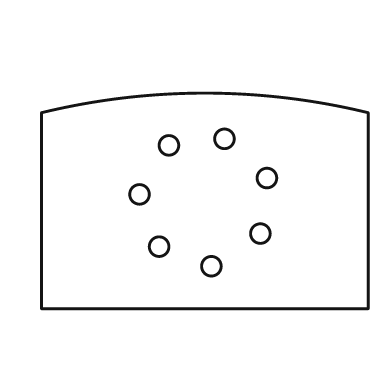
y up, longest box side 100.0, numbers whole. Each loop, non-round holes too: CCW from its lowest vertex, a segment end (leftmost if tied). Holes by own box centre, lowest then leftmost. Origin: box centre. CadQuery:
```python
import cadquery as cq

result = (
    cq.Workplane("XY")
    .moveTo(-50.0, -33.0)
    .lineTo(50.0, -33.0)
    .lineTo(50.0, 27.0)
    .threePointArc((0.0, 33.0), (-50.0, 27.0))
    .close()
    .moveTo(2.0, -20.0)
    .circle(3.0)
    .moveTo(-14.0, -14.0)
    .circle(3.0)
    .moveTo(17.0, -10.0)
    .circle(3.0)
    .moveTo(-20.0, 2.0)
    .circle(3.0)
    .moveTo(19.0, 7.0)
    .circle(3.0)
    .moveTo(-11.0, 17.0)
    .circle(3.0)
    .moveTo(6.0, 19.0)
    .circle(3.0)
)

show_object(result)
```